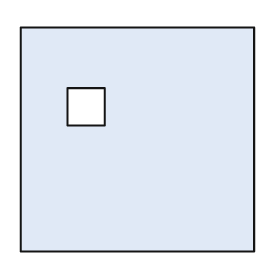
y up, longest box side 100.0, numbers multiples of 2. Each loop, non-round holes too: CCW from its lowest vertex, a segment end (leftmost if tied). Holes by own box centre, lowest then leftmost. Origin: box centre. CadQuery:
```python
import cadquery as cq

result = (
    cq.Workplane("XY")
    .moveTo(-50.0, -48.0)
    .lineTo(50.0, -48.0)
    .lineTo(50.0, 48.0)
    .lineTo(-50.0, 48.0)
    .close()
    .moveTo(-30.0, 6.0)
    .lineTo(-14.0, 6.0)
    .lineTo(-14.0, 22.0)
    .lineTo(-30.0, 22.0)
    .close()
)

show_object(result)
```